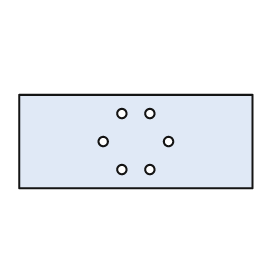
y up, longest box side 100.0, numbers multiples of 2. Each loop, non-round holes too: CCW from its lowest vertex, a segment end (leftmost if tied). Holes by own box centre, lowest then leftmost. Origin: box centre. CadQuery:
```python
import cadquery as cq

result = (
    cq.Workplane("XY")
    .moveTo(-50.0, -20.0)
    .lineTo(50.0, -20.0)
    .lineTo(50.0, 20.0)
    .lineTo(-50.0, 20.0)
    .close()
    .moveTo(-6.0, -12.0)
    .circle(2.0)
    .moveTo(6.0, -12.0)
    .circle(2.0)
    .moveTo(-14.0, 0.0)
    .circle(2.0)
    .moveTo(14.0, 0.0)
    .circle(2.0)
    .moveTo(-6.0, 12.0)
    .circle(2.0)
    .moveTo(6.0, 12.0)
    .circle(2.0)
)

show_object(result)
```